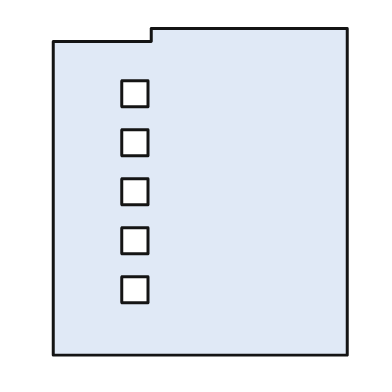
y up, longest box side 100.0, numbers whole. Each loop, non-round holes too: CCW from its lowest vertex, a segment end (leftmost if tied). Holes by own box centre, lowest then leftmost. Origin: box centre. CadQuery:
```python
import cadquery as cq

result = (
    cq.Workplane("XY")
    .moveTo(-45.0, -50.0)
    .lineTo(45.0, -50.0)
    .lineTo(45.0, 50.0)
    .lineTo(-15.0, 50.0)
    .lineTo(-15.0, 46.0)
    .lineTo(-45.0, 46.0)
    .close()
    .moveTo(-24.0, -34.0)
    .lineTo(-16.0, -34.0)
    .lineTo(-16.0, -26.0)
    .lineTo(-24.0, -26.0)
    .close()
    .moveTo(-24.0, -19.0)
    .lineTo(-16.0, -19.0)
    .lineTo(-16.0, -11.0)
    .lineTo(-24.0, -11.0)
    .close()
    .moveTo(-24.0, -4.0)
    .lineTo(-16.0, -4.0)
    .lineTo(-16.0, 4.0)
    .lineTo(-24.0, 4.0)
    .close()
    .moveTo(-24.0, 11.0)
    .lineTo(-16.0, 11.0)
    .lineTo(-16.0, 19.0)
    .lineTo(-24.0, 19.0)
    .close()
    .moveTo(-24.0, 26.0)
    .lineTo(-16.0, 26.0)
    .lineTo(-16.0, 34.0)
    .lineTo(-24.0, 34.0)
    .close()
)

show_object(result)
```